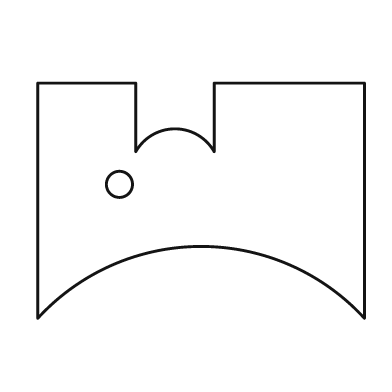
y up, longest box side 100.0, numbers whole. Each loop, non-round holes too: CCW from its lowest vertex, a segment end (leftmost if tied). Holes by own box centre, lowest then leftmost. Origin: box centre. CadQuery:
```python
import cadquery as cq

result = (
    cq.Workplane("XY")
    .moveTo(-50.0, -36.0)
    .threePointArc((0.0, -14.0), (50.0, -36.0))
    .lineTo(50.0, 36.0)
    .lineTo(4.0, 36.0)
    .lineTo(4.0, 15.0)
    .threePointArc((-8.0, 22.0), (-20.0, 15.0))
    .lineTo(-20.0, 36.0)
    .lineTo(-50.0, 36.0)
    .close()
    .moveTo(-25.0, 5.0)
    .circle(4.0)
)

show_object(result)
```